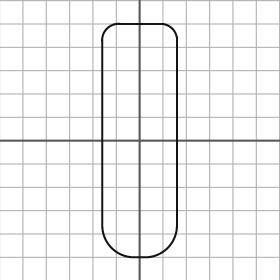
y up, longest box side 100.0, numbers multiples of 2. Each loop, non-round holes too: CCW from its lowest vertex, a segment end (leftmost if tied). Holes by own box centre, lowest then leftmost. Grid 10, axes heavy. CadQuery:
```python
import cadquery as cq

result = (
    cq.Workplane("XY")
    .moveTo(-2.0, -50.0)
    .lineTo(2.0, -50.0)
    .threePointArc((12.0, -46.0), (16.0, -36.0))
    .lineTo(16.0, 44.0)
    .threePointArc((14.0, 48.0), (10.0, 50.0))
    .lineTo(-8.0, 50.0)
    .threePointArc((-14.0, 48.0), (-16.0, 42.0))
    .lineTo(-16.0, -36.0)
    .threePointArc((-12.0, -46.0), (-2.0, -50.0))
    .close()
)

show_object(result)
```